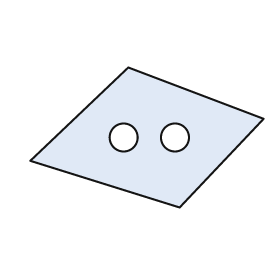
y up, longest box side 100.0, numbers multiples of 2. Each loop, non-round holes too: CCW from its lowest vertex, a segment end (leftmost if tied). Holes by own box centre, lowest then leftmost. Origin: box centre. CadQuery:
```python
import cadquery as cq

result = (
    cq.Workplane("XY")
    .moveTo(14.0, -30.0)
    .lineTo(50.0, 8.0)
    .lineTo(-8.0, 30.0)
    .lineTo(-50.0, -10.0)
    .close()
    .moveTo(-10.0, 0.0)
    .circle(6.0)
    .moveTo(12.0, 0.0)
    .circle(6.0)
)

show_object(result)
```